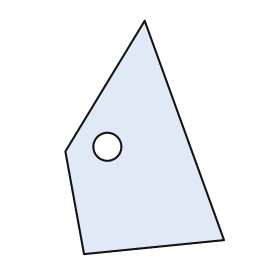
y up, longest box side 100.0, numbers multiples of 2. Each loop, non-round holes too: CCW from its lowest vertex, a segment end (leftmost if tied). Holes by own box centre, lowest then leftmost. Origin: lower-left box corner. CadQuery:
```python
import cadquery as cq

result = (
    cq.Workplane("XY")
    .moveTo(8.0, 0.0)
    .lineTo(68.0, 6.0)
    .lineTo(34.0, 100.0)
    .lineTo(0.0, 44.0)
    .close()
    .moveTo(18.0, 46.0)
    .circle(6.0)
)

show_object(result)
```